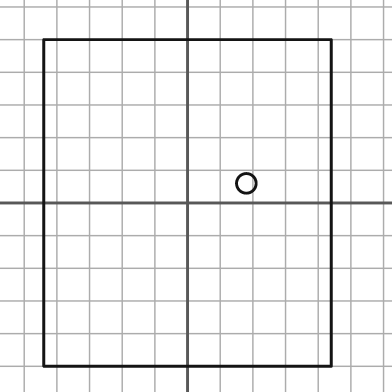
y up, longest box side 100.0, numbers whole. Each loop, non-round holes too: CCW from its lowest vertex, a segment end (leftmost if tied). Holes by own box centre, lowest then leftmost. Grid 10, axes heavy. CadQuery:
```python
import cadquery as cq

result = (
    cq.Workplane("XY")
    .moveTo(-44.0, -50.0)
    .lineTo(44.0, -50.0)
    .lineTo(44.0, 50.0)
    .lineTo(-44.0, 50.0)
    .close()
    .moveTo(18.0, 6.0)
    .circle(3.0)
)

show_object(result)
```